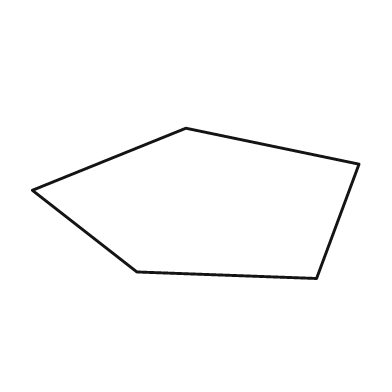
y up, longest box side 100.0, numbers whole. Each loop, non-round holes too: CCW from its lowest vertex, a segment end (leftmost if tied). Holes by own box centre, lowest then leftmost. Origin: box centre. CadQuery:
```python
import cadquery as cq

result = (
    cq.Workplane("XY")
    .moveTo(37.0, -23.0)
    .lineTo(50.0, 12.0)
    .lineTo(-3.0, 23.0)
    .lineTo(-50.0, 4.0)
    .lineTo(-18.0, -21.0)
    .close()
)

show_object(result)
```